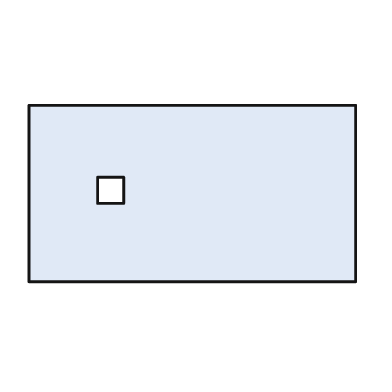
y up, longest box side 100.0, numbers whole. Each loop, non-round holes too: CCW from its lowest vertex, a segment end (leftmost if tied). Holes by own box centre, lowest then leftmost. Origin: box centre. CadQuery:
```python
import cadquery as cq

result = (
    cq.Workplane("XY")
    .moveTo(-50.0, -27.0)
    .lineTo(50.0, -27.0)
    .lineTo(50.0, 27.0)
    .lineTo(-50.0, 27.0)
    .close()
    .moveTo(-29.0, -3.0)
    .lineTo(-21.0, -3.0)
    .lineTo(-21.0, 5.0)
    .lineTo(-29.0, 5.0)
    .close()
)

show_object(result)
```